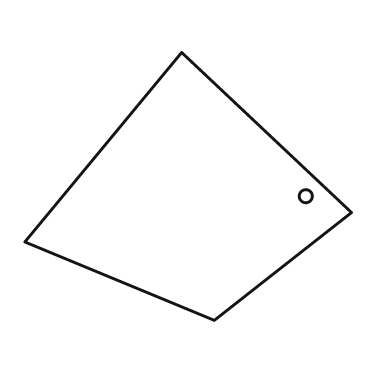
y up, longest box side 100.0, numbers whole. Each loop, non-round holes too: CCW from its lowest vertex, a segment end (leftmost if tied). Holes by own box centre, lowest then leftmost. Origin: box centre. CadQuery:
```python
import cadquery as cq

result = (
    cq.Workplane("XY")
    .moveTo(8.0, -41.0)
    .lineTo(50.0, -8.0)
    .lineTo(-2.0, 41.0)
    .lineTo(-50.0, -17.0)
    .close()
    .moveTo(36.0, -3.0)
    .circle(2.0)
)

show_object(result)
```